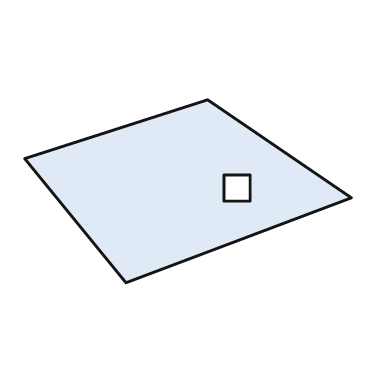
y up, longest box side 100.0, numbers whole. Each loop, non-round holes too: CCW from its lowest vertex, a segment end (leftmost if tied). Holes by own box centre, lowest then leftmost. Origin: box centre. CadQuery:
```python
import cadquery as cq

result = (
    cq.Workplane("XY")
    .moveTo(-19.0, -28.0)
    .lineTo(50.0, -2.0)
    .lineTo(6.0, 28.0)
    .lineTo(-50.0, 10.0)
    .close()
    .moveTo(11.0, -3.0)
    .lineTo(19.0, -3.0)
    .lineTo(19.0, 5.0)
    .lineTo(11.0, 5.0)
    .close()
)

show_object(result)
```